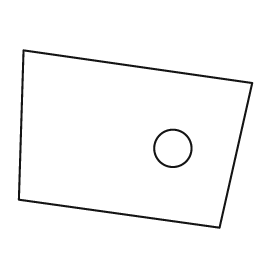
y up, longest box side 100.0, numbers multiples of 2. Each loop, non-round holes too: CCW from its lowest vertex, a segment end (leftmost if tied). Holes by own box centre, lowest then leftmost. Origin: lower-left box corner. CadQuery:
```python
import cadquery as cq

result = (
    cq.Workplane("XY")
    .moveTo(86.0, 0.0)
    .lineTo(100.0, 62.0)
    .lineTo(2.0, 76.0)
    .lineTo(0.0, 12.0)
    .close()
    .moveTo(66.0, 34.0)
    .circle(8.0)
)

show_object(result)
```